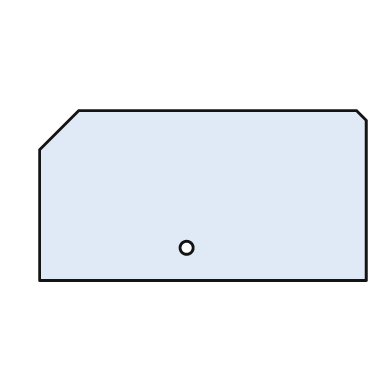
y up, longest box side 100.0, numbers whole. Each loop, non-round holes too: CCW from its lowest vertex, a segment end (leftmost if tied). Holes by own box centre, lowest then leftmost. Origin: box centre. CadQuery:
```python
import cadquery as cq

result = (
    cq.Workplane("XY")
    .moveTo(-50.0, -26.0)
    .lineTo(50.0, -26.0)
    .lineTo(50.0, 23.0)
    .lineTo(47.0, 26.0)
    .lineTo(-38.0, 26.0)
    .lineTo(-50.0, 14.0)
    .close()
    .moveTo(-5.0, -16.0)
    .circle(2.0)
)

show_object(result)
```